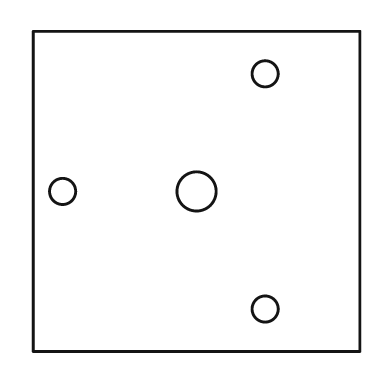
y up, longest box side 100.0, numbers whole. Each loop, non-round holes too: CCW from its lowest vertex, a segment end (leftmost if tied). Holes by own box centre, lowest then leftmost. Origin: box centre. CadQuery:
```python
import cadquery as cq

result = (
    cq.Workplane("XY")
    .moveTo(-50.0, -49.0)
    .lineTo(50.0, -49.0)
    .lineTo(50.0, 49.0)
    .lineTo(-50.0, 49.0)
    .close()
    .moveTo(21.0, -36.0)
    .circle(4.0)
    .moveTo(-41.0, 0.0)
    .circle(4.0)
    .moveTo(0.0, 0.0)
    .circle(6.0)
    .moveTo(21.0, 36.0)
    .circle(4.0)
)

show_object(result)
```